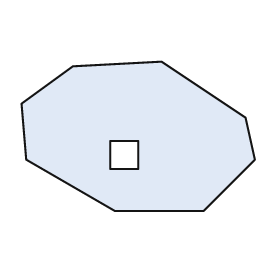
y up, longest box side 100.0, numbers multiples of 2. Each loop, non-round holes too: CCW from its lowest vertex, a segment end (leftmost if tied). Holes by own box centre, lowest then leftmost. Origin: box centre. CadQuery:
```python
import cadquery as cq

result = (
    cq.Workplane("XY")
    .moveTo(-10.0, -32.0)
    .lineTo(28.0, -32.0)
    .lineTo(50.0, -10.0)
    .lineTo(46.0, 8.0)
    .lineTo(10.0, 32.0)
    .lineTo(-28.0, 30.0)
    .lineTo(-50.0, 14.0)
    .lineTo(-48.0, -10.0)
    .close()
    .moveTo(-12.0, -14.0)
    .lineTo(0.0, -14.0)
    .lineTo(0.0, -2.0)
    .lineTo(-12.0, -2.0)
    .close()
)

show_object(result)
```